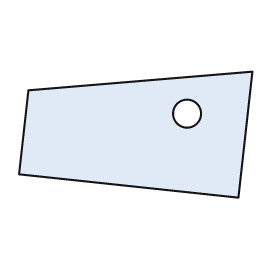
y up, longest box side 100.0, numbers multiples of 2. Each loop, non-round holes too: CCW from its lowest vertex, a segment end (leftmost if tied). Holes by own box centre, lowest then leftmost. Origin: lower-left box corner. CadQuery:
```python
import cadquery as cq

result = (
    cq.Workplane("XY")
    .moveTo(94.0, 0.0)
    .lineTo(100.0, 54.0)
    .lineTo(4.0, 46.0)
    .lineTo(0.0, 10.0)
    .close()
    .moveTo(72.0, 36.0)
    .circle(6.0)
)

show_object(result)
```